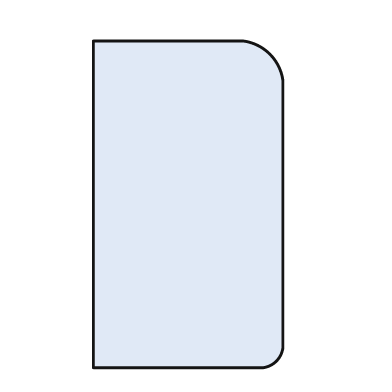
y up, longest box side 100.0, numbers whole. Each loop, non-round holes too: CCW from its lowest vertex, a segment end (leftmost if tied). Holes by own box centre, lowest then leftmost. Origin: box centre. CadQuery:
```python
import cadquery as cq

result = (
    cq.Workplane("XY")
    .moveTo(-29.0, -50.0)
    .lineTo(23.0, -50.0)
    .threePointArc((27.0, -48.0), (29.0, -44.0))
    .lineTo(29.0, 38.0)
    .threePointArc((25.0, 46.0), (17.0, 50.0))
    .lineTo(-29.0, 50.0)
    .close()
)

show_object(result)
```